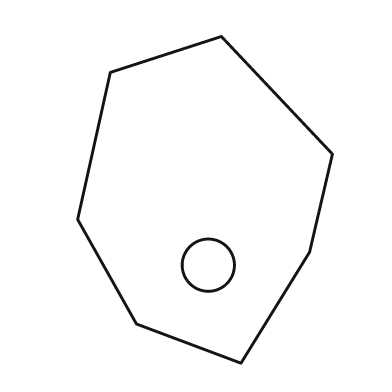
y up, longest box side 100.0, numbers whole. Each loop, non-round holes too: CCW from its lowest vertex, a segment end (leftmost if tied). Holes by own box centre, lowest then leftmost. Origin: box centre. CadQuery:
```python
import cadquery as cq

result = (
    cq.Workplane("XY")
    .moveTo(11.0, -50.0)
    .lineTo(32.0, -16.0)
    .lineTo(39.0, 14.0)
    .lineTo(5.0, 50.0)
    .lineTo(-29.0, 39.0)
    .lineTo(-39.0, -6.0)
    .lineTo(-21.0, -38.0)
    .close()
    .moveTo(1.0, -20.0)
    .circle(8.0)
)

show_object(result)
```